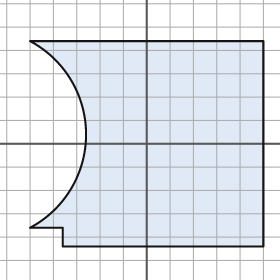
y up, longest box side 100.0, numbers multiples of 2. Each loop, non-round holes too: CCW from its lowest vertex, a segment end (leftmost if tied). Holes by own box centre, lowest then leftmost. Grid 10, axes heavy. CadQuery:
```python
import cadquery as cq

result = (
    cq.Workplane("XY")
    .moveTo(-36.0, -44.0)
    .lineTo(50.0, -44.0)
    .lineTo(50.0, 44.0)
    .lineTo(-50.0, 44.0)
    .threePointArc((-26.0, 4.0), (-50.0, -36.0))
    .lineTo(-36.0, -36.0)
    .close()
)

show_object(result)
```